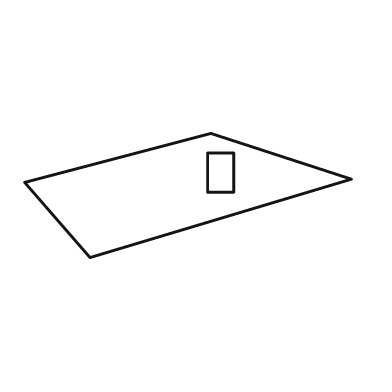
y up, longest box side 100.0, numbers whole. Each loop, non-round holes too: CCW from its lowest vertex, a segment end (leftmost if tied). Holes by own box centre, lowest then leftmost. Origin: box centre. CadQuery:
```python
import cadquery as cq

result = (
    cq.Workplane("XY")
    .moveTo(-30.0, -19.0)
    .lineTo(50.0, 5.0)
    .lineTo(7.0, 19.0)
    .lineTo(-50.0, 4.0)
    .close()
    .moveTo(6.0, 1.0)
    .lineTo(14.0, 1.0)
    .lineTo(14.0, 13.0)
    .lineTo(6.0, 13.0)
    .close()
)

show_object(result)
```